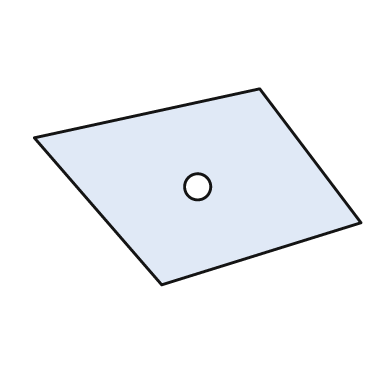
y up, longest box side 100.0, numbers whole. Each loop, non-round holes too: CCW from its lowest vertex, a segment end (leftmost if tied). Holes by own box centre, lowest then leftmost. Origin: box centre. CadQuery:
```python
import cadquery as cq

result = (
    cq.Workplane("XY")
    .moveTo(-11.0, -30.0)
    .lineTo(50.0, -11.0)
    .lineTo(19.0, 30.0)
    .lineTo(-50.0, 15.0)
    .close()
    .moveTo(0.0, 0.0)
    .circle(4.0)
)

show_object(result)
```